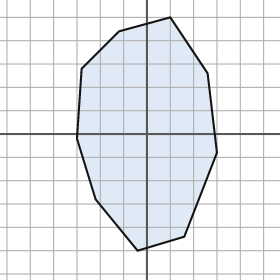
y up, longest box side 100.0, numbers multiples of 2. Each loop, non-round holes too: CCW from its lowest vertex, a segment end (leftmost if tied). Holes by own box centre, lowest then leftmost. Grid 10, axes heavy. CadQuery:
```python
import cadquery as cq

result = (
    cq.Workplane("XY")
    .moveTo(-4.0, -50.0)
    .lineTo(16.0, -44.0)
    .lineTo(30.0, -8.0)
    .lineTo(26.0, 26.0)
    .lineTo(10.0, 50.0)
    .lineTo(-12.0, 44.0)
    .lineTo(-28.0, 28.0)
    .lineTo(-30.0, -2.0)
    .lineTo(-22.0, -28.0)
    .close()
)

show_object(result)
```